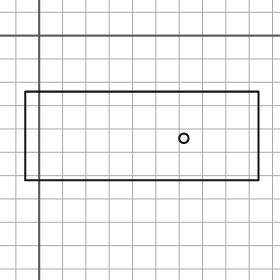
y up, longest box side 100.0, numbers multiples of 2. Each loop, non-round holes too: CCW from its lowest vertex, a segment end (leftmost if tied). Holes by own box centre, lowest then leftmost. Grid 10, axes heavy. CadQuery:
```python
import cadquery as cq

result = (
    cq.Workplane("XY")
    .moveTo(-6.0, -62.0)
    .lineTo(94.0, -62.0)
    .lineTo(94.0, -24.0)
    .lineTo(-6.0, -24.0)
    .close()
    .moveTo(62.0, -44.0)
    .circle(2.0)
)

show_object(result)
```